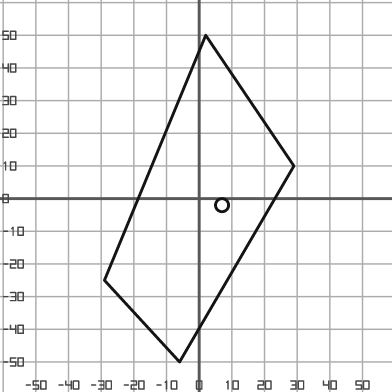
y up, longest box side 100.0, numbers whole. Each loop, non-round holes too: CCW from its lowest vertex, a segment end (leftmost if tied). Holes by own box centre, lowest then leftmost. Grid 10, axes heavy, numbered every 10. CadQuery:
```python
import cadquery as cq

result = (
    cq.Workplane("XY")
    .moveTo(-6.0, -50.0)
    .lineTo(29.0, 10.0)
    .lineTo(2.0, 50.0)
    .lineTo(-29.0, -25.0)
    .close()
    .moveTo(7.0, -2.0)
    .circle(2.0)
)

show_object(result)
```